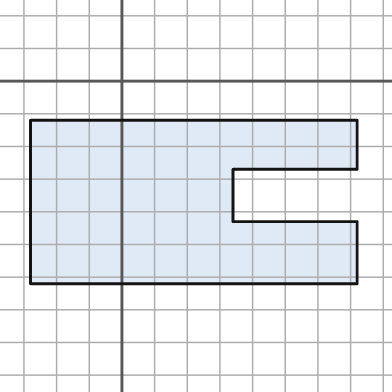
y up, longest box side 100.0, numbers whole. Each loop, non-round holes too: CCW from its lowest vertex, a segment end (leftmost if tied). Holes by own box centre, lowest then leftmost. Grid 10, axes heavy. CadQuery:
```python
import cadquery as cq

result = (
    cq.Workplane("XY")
    .moveTo(-28.0, -62.0)
    .lineTo(72.0, -62.0)
    .lineTo(72.0, -43.0)
    .lineTo(34.0, -43.0)
    .lineTo(34.0, -27.0)
    .lineTo(72.0, -27.0)
    .lineTo(72.0, -12.0)
    .lineTo(-28.0, -12.0)
    .close()
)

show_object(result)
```